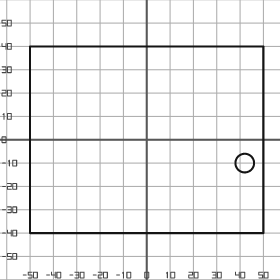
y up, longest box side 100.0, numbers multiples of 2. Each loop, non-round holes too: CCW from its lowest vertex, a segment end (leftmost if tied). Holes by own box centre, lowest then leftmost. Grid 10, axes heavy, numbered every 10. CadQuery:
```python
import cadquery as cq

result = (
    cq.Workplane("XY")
    .moveTo(-50.0, -40.0)
    .lineTo(50.0, -40.0)
    .lineTo(50.0, 40.0)
    .lineTo(-50.0, 40.0)
    .close()
    .moveTo(42.0, -10.0)
    .circle(4.0)
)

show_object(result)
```